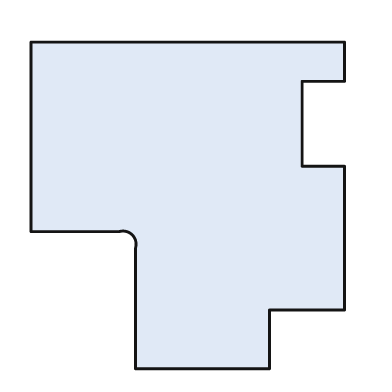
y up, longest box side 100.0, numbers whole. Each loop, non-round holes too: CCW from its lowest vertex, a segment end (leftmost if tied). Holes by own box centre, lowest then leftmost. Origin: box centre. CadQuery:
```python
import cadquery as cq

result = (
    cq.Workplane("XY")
    .moveTo(-16.0, -50.0)
    .lineTo(25.0, -50.0)
    .lineTo(25.0, -32.0)
    .lineTo(48.0, -32.0)
    .lineTo(48.0, 12.0)
    .lineTo(35.0, 12.0)
    .lineTo(35.0, 38.0)
    .lineTo(48.0, 38.0)
    .lineTo(48.0, 50.0)
    .lineTo(-48.0, 50.0)
    .lineTo(-48.0, -8.0)
    .lineTo(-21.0, -8.0)
    .threePointArc((-17.0, -9.0), (-16.0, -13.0))
    .close()
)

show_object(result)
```